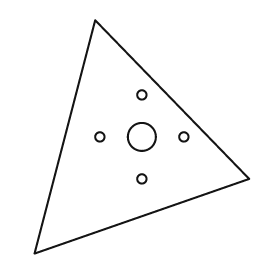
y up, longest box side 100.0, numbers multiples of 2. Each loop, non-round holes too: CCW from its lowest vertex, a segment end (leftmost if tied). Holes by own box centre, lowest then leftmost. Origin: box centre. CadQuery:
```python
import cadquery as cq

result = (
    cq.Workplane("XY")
    .moveTo(-46.0, -50.0)
    .lineTo(46.0, -18.0)
    .lineTo(-20.0, 50.0)
    .close()
    .moveTo(0.0, -18.0)
    .circle(2.0)
    .moveTo(-18.0, 0.0)
    .circle(2.0)
    .moveTo(0.0, 0.0)
    .circle(6.0)
    .moveTo(18.0, 0.0)
    .circle(2.0)
    .moveTo(0.0, 18.0)
    .circle(2.0)
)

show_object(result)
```